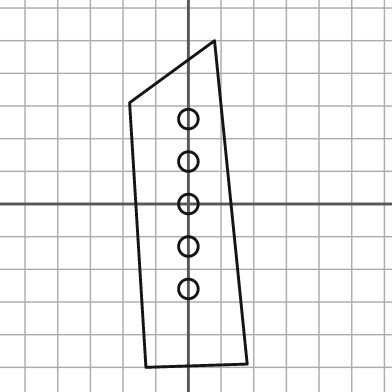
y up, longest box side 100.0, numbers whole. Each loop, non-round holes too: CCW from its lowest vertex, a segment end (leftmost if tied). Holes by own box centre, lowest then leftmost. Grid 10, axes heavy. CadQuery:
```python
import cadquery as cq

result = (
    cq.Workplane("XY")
    .moveTo(-13.0, -50.0)
    .lineTo(18.0, -49.0)
    .lineTo(8.0, 50.0)
    .lineTo(-18.0, 31.0)
    .close()
    .moveTo(0.0, -26.0)
    .circle(3.0)
    .moveTo(0.0, -13.0)
    .circle(3.0)
    .moveTo(0.0, 0.0)
    .circle(3.0)
    .moveTo(0.0, 13.0)
    .circle(3.0)
    .moveTo(0.0, 26.0)
    .circle(3.0)
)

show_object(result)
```